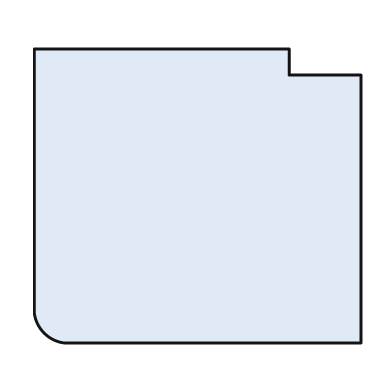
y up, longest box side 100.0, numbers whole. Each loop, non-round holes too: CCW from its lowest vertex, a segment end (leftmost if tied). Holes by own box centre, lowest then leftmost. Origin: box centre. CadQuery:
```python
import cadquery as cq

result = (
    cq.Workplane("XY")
    .moveTo(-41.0, -45.0)
    .lineTo(50.0, -45.0)
    .lineTo(50.0, 37.0)
    .lineTo(28.0, 37.0)
    .lineTo(28.0, 45.0)
    .lineTo(-50.0, 45.0)
    .lineTo(-50.0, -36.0)
    .threePointArc((-47.0, -42.0), (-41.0, -45.0))
    .close()
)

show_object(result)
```